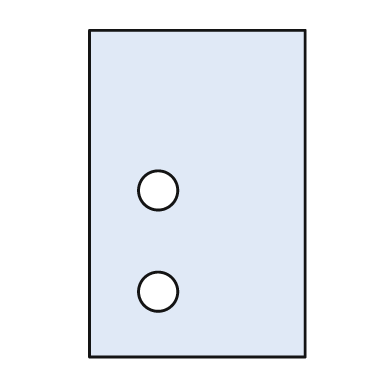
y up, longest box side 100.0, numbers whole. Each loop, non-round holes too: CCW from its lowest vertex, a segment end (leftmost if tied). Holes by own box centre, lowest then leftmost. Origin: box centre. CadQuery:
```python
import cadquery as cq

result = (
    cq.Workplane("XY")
    .moveTo(-33.0, -50.0)
    .lineTo(33.0, -50.0)
    .lineTo(33.0, 50.0)
    .lineTo(-33.0, 50.0)
    .close()
    .moveTo(-12.0, -30.0)
    .circle(6.0)
    .moveTo(-12.0, 1.0)
    .circle(6.0)
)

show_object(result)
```